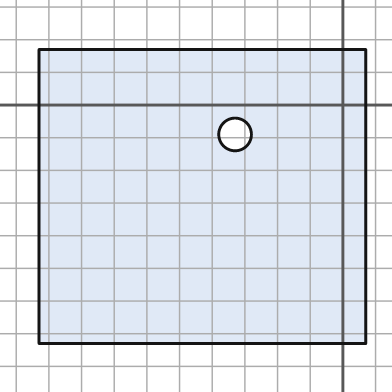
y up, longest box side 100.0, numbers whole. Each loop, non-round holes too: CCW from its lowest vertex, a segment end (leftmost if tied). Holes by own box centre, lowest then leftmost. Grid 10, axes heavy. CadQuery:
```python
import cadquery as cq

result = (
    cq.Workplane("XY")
    .moveTo(-93.0, -73.0)
    .lineTo(7.0, -73.0)
    .lineTo(7.0, 17.0)
    .lineTo(-93.0, 17.0)
    .close()
    .moveTo(-33.0, -9.0)
    .circle(5.0)
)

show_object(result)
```